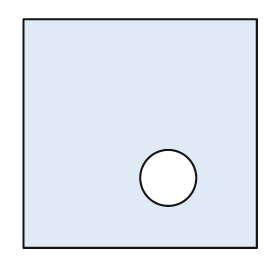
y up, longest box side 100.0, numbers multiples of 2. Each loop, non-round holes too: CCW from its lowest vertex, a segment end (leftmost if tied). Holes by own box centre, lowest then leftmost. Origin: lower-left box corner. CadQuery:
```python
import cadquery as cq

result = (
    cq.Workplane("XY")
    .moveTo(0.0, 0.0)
    .lineTo(100.0, 0.0)
    .lineTo(100.0, 98.0)
    .lineTo(0.0, 98.0)
    .close()
    .moveTo(62.0, 30.0)
    .circle(12.0)
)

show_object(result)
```